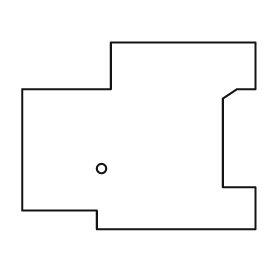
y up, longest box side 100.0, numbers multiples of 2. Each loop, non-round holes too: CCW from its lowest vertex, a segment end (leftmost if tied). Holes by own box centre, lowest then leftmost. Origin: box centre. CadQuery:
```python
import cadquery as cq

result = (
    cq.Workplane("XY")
    .moveTo(-18.0, -40.0)
    .lineTo(50.0, -40.0)
    .lineTo(50.0, -22.0)
    .lineTo(36.0, -22.0)
    .lineTo(36.0, 16.0)
    .lineTo(42.0, 20.0)
    .lineTo(50.0, 20.0)
    .lineTo(50.0, 40.0)
    .lineTo(-12.0, 40.0)
    .lineTo(-12.0, 20.0)
    .lineTo(-50.0, 20.0)
    .lineTo(-50.0, -32.0)
    .lineTo(-18.0, -32.0)
    .close()
    .moveTo(-16.0, -14.0)
    .circle(2.0)
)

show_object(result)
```